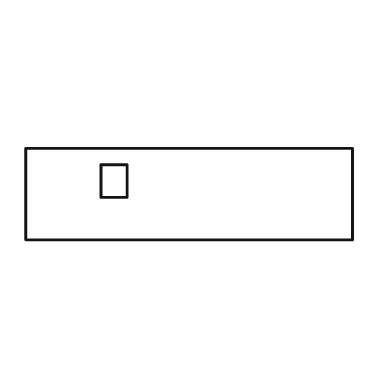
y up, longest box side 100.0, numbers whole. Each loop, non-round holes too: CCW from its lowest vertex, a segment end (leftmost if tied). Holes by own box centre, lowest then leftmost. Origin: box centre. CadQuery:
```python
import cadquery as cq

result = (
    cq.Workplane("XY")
    .moveTo(-50.0, -14.0)
    .lineTo(50.0, -14.0)
    .lineTo(50.0, 14.0)
    .lineTo(-50.0, 14.0)
    .close()
    .moveTo(-27.0, -1.0)
    .lineTo(-19.0, -1.0)
    .lineTo(-19.0, 9.0)
    .lineTo(-27.0, 9.0)
    .close()
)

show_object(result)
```